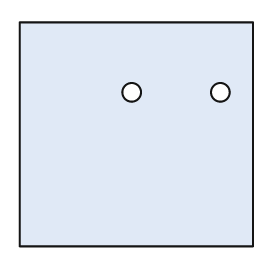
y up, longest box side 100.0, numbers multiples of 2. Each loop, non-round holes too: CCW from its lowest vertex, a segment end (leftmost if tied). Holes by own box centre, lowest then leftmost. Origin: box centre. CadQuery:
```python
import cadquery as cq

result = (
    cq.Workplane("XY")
    .moveTo(-50.0, -48.0)
    .lineTo(50.0, -48.0)
    .lineTo(50.0, 48.0)
    .lineTo(-50.0, 48.0)
    .close()
    .moveTo(-2.0, 18.0)
    .circle(4.0)
    .moveTo(36.0, 18.0)
    .circle(4.0)
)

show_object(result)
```